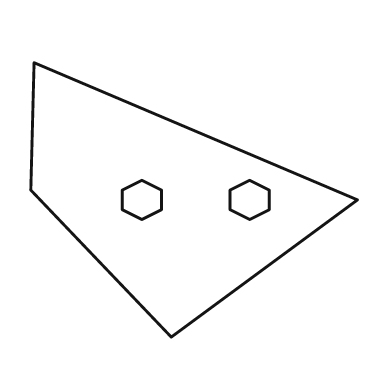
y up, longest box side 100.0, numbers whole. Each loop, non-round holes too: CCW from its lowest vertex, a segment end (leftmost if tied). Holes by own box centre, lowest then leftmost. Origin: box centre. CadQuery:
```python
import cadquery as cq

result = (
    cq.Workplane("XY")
    .moveTo(-7.0, -42.0)
    .lineTo(50.0, 0.0)
    .lineTo(-49.0, 42.0)
    .lineTo(-50.0, 3.0)
    .close()
    .moveTo(-16.0, -6.0)
    .lineTo(-10.0, -3.0)
    .lineTo(-10.0, 3.0)
    .lineTo(-16.0, 6.0)
    .lineTo(-22.0, 3.0)
    .lineTo(-22.0, -3.0)
    .close()
    .moveTo(17.0, -6.0)
    .lineTo(23.0, -3.0)
    .lineTo(23.0, 3.0)
    .lineTo(17.0, 6.0)
    .lineTo(11.0, 3.0)
    .lineTo(11.0, -3.0)
    .close()
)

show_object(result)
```